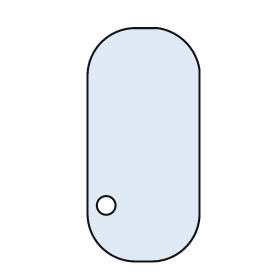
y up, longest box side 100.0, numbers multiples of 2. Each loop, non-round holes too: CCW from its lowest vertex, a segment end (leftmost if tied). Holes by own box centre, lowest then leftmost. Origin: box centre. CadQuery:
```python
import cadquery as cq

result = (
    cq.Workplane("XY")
    .moveTo(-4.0, -50.0)
    .lineTo(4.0, -50.0)
    .threePointArc((18.0, -44.0), (24.0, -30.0))
    .lineTo(24.0, 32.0)
    .threePointArc((18.0, 44.0), (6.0, 50.0))
    .lineTo(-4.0, 50.0)
    .threePointArc((-18.0, 44.0), (-24.0, 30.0))
    .lineTo(-24.0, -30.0)
    .threePointArc((-18.0, -44.0), (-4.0, -50.0))
    .close()
    .moveTo(-16.0, -26.0)
    .circle(4.0)
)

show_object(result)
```